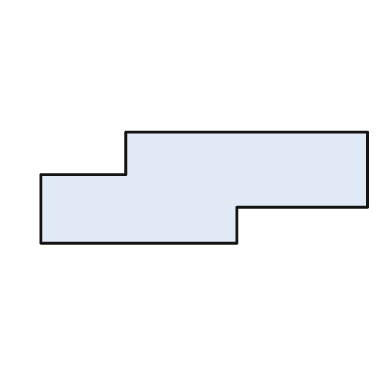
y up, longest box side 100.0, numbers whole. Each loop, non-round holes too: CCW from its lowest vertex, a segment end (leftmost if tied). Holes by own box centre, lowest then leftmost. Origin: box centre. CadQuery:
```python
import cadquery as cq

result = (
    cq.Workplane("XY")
    .moveTo(-50.0, -17.0)
    .lineTo(10.0, -17.0)
    .lineTo(10.0, -6.0)
    .lineTo(50.0, -6.0)
    .lineTo(50.0, 17.0)
    .lineTo(-24.0, 17.0)
    .lineTo(-24.0, 4.0)
    .lineTo(-50.0, 4.0)
    .close()
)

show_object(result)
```